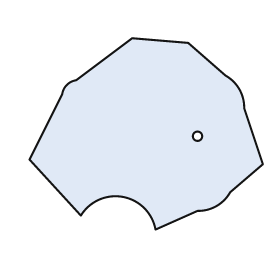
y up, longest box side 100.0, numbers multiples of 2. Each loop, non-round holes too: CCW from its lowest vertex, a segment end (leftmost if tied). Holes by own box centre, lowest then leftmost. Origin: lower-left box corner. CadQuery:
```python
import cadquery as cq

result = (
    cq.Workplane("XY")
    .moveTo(54.0, 0.0)
    .lineTo(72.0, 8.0)
    .threePointArc((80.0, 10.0), (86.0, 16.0))
    .lineTo(100.0, 28.0)
    .lineTo(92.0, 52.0)
    .threePointArc((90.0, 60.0), (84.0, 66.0))
    .lineTo(68.0, 80.0)
    .lineTo(44.0, 82.0)
    .lineTo(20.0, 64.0)
    .threePointArc((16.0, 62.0), (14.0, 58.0))
    .lineTo(0.0, 30.0)
    .lineTo(22.0, 6.0)
    .threePointArc((40.0, 14.0), (54.0, 0.0))
    .close()
    .moveTo(72.0, 40.0)
    .circle(2.0)
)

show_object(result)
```